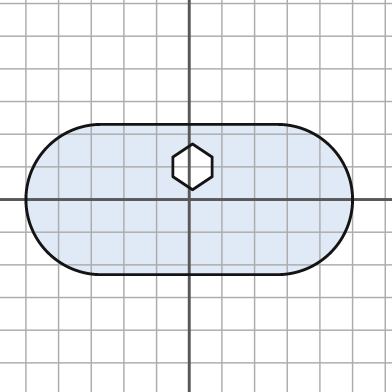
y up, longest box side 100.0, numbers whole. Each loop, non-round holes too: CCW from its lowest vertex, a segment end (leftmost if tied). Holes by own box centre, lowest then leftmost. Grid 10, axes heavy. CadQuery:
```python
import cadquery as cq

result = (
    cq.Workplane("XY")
    .moveTo(-27.0, -23.0)
    .lineTo(27.0, -23.0)
    .threePointArc((50.0, 0.0), (27.0, 23.0))
    .lineTo(-27.0, 23.0)
    .threePointArc((-50.0, 0.0), (-27.0, -23.0))
    .close()
    .moveTo(1.0, 3.0)
    .lineTo(7.0, 7.0)
    .lineTo(7.0, 13.0)
    .lineTo(1.0, 17.0)
    .lineTo(-5.0, 13.0)
    .lineTo(-5.0, 7.0)
    .close()
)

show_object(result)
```